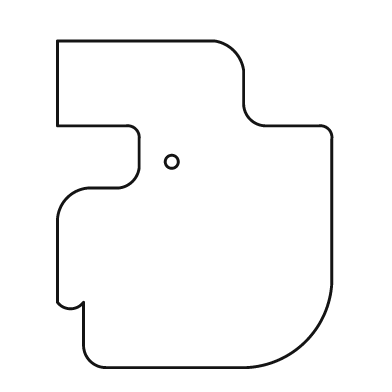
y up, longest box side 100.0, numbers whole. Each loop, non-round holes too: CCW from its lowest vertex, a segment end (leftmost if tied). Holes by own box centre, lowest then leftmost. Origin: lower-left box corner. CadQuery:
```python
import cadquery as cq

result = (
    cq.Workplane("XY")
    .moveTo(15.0, 0.0)
    .lineTo(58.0, 0.0)
    .threePointArc((76.0, 8.0), (84.0, 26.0))
    .lineTo(84.0, 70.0)
    .threePointArc((83.0, 73.0), (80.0, 74.0))
    .lineTo(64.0, 74.0)
    .threePointArc((59.0, 76.0), (57.0, 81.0))
    .lineTo(57.0, 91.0)
    .threePointArc((54.0, 97.0), (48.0, 100.0))
    .lineTo(0.0, 100.0)
    .lineTo(0.0, 74.0)
    .lineTo(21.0, 74.0)
    .threePointArc((24.0, 73.0), (25.0, 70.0))
    .lineTo(25.0, 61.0)
    .threePointArc((23.0, 57.0), (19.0, 55.0))
    .lineTo(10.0, 55.0)
    .threePointArc((3.0, 52.0), (0.0, 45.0))
    .lineTo(0.0, 20.0)
    .threePointArc((4.0, 18.0), (8.0, 20.0))
    .lineTo(8.0, 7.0)
    .threePointArc((10.0, 2.0), (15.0, 0.0))
    .close()
    .moveTo(35.0, 63.0)
    .circle(2.0)
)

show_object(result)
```